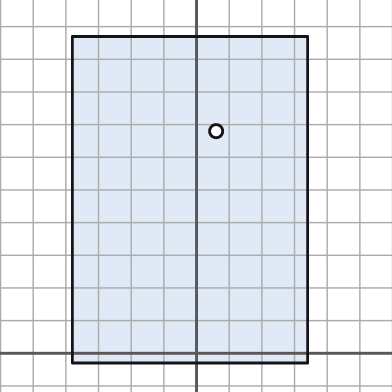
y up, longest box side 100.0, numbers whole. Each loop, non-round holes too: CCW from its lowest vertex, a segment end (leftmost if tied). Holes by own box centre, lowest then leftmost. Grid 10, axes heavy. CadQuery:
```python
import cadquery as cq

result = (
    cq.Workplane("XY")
    .moveTo(-38.0, -3.0)
    .lineTo(34.0, -3.0)
    .lineTo(34.0, 97.0)
    .lineTo(-38.0, 97.0)
    .close()
    .moveTo(6.0, 68.0)
    .circle(2.0)
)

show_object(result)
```